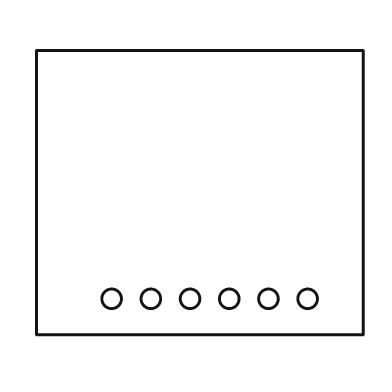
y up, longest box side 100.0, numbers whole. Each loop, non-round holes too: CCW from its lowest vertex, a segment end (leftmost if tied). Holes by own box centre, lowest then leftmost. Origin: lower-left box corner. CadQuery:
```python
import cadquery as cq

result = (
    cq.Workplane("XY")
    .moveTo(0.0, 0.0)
    .lineTo(100.0, 0.0)
    .lineTo(100.0, 87.0)
    .lineTo(0.0, 87.0)
    .close()
    .moveTo(23.0, 11.0)
    .circle(3.0)
    .moveTo(35.0, 11.0)
    .circle(3.0)
    .moveTo(47.0, 11.0)
    .circle(3.0)
    .moveTo(59.0, 11.0)
    .circle(3.0)
    .moveTo(71.0, 11.0)
    .circle(3.0)
    .moveTo(83.0, 11.0)
    .circle(3.0)
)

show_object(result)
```